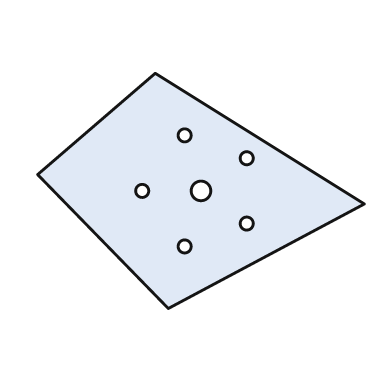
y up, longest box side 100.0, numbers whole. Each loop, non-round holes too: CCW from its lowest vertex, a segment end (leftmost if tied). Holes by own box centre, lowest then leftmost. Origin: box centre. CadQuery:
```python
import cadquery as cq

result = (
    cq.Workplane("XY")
    .moveTo(-10.0, -36.0)
    .lineTo(50.0, -4.0)
    .lineTo(-14.0, 36.0)
    .lineTo(-50.0, 5.0)
    .close()
    .moveTo(-5.0, -17.0)
    .circle(2.0)
    .moveTo(14.0, -10.0)
    .circle(2.0)
    .moveTo(-18.0, 0.0)
    .circle(2.0)
    .moveTo(0.0, 0.0)
    .circle(3.0)
    .moveTo(14.0, 10.0)
    .circle(2.0)
    .moveTo(-5.0, 17.0)
    .circle(2.0)
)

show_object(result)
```